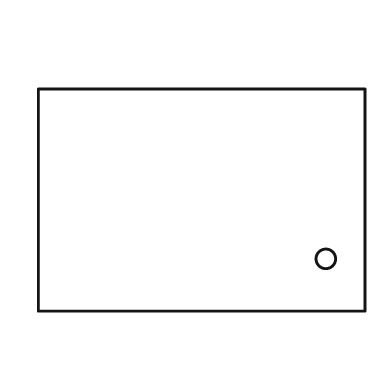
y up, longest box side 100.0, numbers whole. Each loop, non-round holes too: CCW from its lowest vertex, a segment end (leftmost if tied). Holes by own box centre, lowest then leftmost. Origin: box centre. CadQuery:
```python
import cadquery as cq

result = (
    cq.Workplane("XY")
    .moveTo(-50.0, -34.0)
    .lineTo(50.0, -34.0)
    .lineTo(50.0, 34.0)
    .lineTo(-50.0, 34.0)
    .close()
    .moveTo(38.0, -18.0)
    .circle(3.0)
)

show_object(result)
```